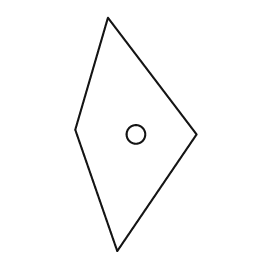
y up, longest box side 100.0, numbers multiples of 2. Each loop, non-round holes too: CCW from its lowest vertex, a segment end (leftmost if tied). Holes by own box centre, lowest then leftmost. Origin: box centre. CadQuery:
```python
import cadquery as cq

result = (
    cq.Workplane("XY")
    .moveTo(-8.0, -50.0)
    .lineTo(26.0, 0.0)
    .lineTo(-12.0, 50.0)
    .lineTo(-26.0, 2.0)
    .close()
    .moveTo(0.0, 0.0)
    .circle(4.0)
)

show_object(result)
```